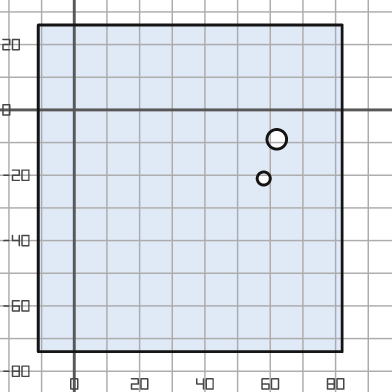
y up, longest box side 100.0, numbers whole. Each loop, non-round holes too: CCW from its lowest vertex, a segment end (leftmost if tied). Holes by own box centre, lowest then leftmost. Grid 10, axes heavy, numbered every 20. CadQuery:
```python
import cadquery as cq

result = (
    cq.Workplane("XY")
    .moveTo(-11.0, -74.0)
    .lineTo(82.0, -74.0)
    .lineTo(82.0, 26.0)
    .lineTo(-11.0, 26.0)
    .close()
    .moveTo(58.0, -21.0)
    .circle(2.0)
    .moveTo(62.0, -9.0)
    .circle(3.0)
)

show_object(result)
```